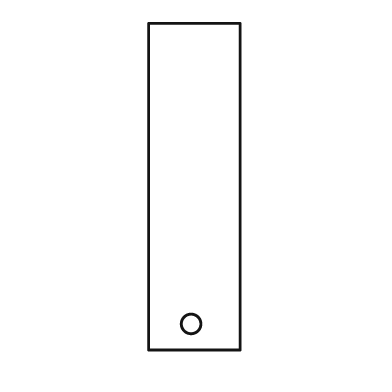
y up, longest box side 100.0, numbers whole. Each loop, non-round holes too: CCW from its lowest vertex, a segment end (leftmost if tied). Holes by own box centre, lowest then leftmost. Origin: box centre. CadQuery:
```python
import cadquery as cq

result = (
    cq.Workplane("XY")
    .moveTo(-14.0, -50.0)
    .lineTo(14.0, -50.0)
    .lineTo(14.0, 50.0)
    .lineTo(-14.0, 50.0)
    .close()
    .moveTo(-1.0, -42.0)
    .circle(3.0)
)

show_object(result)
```